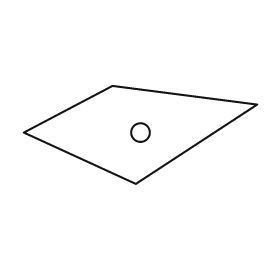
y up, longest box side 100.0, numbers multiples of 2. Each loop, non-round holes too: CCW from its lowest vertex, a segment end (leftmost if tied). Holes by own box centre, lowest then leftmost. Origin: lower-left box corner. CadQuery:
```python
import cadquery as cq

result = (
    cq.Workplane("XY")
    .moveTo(48.0, 0.0)
    .lineTo(100.0, 34.0)
    .lineTo(38.0, 42.0)
    .lineTo(0.0, 22.0)
    .close()
    .moveTo(50.0, 22.0)
    .circle(4.0)
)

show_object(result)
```